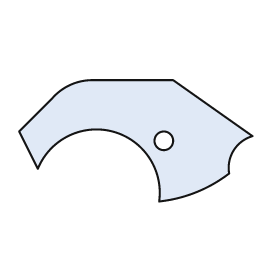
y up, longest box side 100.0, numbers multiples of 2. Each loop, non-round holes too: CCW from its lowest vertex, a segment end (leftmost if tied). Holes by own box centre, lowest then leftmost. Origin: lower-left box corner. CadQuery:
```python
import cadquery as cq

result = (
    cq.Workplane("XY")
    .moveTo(60.0, 0.0)
    .threePointArc((76.0, 4.0), (90.0, 12.0))
    .threePointArc((92.0, 22.0), (100.0, 28.0))
    .lineTo(66.0, 52.0)
    .lineTo(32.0, 52.0)
    .threePointArc((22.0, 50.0), (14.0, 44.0))
    .lineTo(0.0, 30.0)
    .lineTo(8.0, 14.0)
    .threePointArc((40.0, 30.0), (60.0, 0.0))
    .close()
    .moveTo(62.0, 26.0)
    .circle(4.0)
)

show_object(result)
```